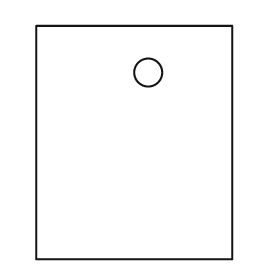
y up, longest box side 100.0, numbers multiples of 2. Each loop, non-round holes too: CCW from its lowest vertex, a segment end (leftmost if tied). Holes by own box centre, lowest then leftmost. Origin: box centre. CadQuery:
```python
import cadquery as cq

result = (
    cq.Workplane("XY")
    .moveTo(-42.0, -50.0)
    .lineTo(42.0, -50.0)
    .lineTo(42.0, 50.0)
    .lineTo(-42.0, 50.0)
    .close()
    .moveTo(6.0, 30.0)
    .circle(6.0)
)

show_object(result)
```